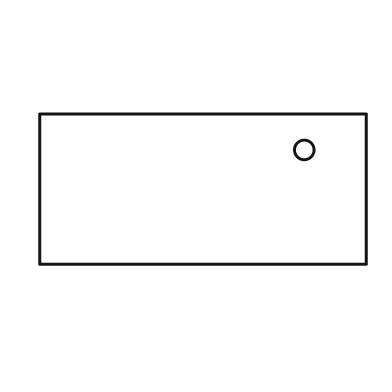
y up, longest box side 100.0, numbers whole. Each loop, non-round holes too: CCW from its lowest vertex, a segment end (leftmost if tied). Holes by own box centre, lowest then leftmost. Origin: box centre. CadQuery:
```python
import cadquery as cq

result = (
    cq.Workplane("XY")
    .moveTo(-50.0, -23.0)
    .lineTo(50.0, -23.0)
    .lineTo(50.0, 23.0)
    .lineTo(-50.0, 23.0)
    .close()
    .moveTo(31.0, 12.0)
    .circle(3.0)
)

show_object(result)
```